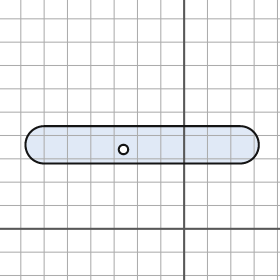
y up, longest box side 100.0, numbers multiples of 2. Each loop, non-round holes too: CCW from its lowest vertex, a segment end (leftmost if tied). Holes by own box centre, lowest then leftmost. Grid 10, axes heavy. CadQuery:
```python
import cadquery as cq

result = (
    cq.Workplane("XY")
    .moveTo(-60.0, 28.0)
    .lineTo(24.0, 28.0)
    .threePointArc((32.0, 36.0), (24.0, 44.0))
    .lineTo(-60.0, 44.0)
    .threePointArc((-68.0, 36.0), (-60.0, 28.0))
    .close()
    .moveTo(-26.0, 34.0)
    .circle(2.0)
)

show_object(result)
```